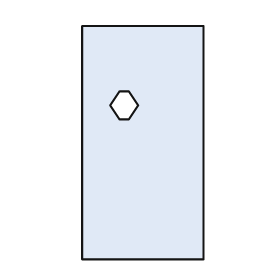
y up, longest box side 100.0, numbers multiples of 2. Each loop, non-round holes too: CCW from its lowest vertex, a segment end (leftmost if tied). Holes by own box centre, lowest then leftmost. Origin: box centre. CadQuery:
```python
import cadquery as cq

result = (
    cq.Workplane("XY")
    .moveTo(-26.0, -50.0)
    .lineTo(26.0, -50.0)
    .lineTo(26.0, 50.0)
    .lineTo(-26.0, 50.0)
    .close()
    .moveTo(-10.0, 10.0)
    .lineTo(-6.0, 10.0)
    .lineTo(-2.0, 16.0)
    .lineTo(-6.0, 22.0)
    .lineTo(-10.0, 22.0)
    .lineTo(-14.0, 16.0)
    .close()
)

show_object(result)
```